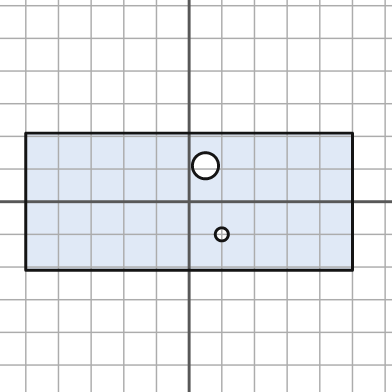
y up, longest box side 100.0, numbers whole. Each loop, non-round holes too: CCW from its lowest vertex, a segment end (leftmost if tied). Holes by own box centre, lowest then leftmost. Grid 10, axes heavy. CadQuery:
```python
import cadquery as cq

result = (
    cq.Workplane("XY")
    .moveTo(-50.0, -21.0)
    .lineTo(50.0, -21.0)
    .lineTo(50.0, 21.0)
    .lineTo(-50.0, 21.0)
    .close()
    .moveTo(10.0, -10.0)
    .circle(2.0)
    .moveTo(5.0, 11.0)
    .circle(4.0)
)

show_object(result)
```